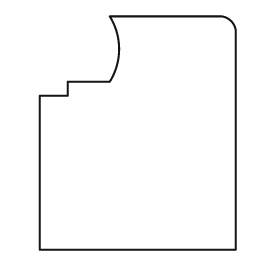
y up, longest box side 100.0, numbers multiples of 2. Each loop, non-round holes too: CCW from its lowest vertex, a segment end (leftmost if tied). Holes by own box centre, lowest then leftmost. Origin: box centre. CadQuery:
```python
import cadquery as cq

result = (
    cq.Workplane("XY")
    .moveTo(-42.0, -50.0)
    .lineTo(42.0, -50.0)
    .lineTo(42.0, 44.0)
    .threePointArc((40.0, 48.0), (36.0, 50.0))
    .lineTo(-12.0, 50.0)
    .threePointArc((-8.0, 36.0), (-12.0, 22.0))
    .lineTo(-30.0, 22.0)
    .lineTo(-30.0, 16.0)
    .lineTo(-42.0, 16.0)
    .close()
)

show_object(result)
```